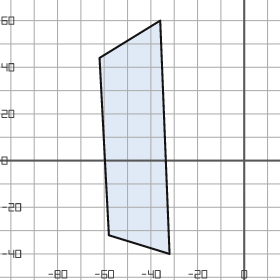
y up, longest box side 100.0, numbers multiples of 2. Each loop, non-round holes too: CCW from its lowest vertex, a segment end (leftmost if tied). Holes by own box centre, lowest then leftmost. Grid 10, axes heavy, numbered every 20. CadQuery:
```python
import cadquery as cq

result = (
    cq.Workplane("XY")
    .moveTo(-32.0, -40.0)
    .lineTo(-36.0, 60.0)
    .lineTo(-62.0, 44.0)
    .lineTo(-58.0, -32.0)
    .close()
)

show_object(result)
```